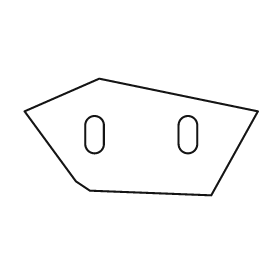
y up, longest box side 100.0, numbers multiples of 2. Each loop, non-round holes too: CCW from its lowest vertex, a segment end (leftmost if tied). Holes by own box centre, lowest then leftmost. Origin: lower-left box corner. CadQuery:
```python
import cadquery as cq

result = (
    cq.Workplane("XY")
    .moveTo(80.0, 0.0)
    .lineTo(100.0, 36.0)
    .lineTo(32.0, 50.0)
    .lineTo(0.0, 36.0)
    .lineTo(22.0, 6.0)
    .lineTo(28.0, 2.0)
    .close()
    .moveTo(26.0, 22.0)
    .threePointArc((30.0, 18.0), (34.0, 22.0))
    .lineTo(34.0, 30.0)
    .threePointArc((30.0, 34.0), (26.0, 30.0))
    .close()
    .moveTo(66.0, 22.0)
    .threePointArc((70.0, 18.0), (74.0, 22.0))
    .lineTo(74.0, 30.0)
    .threePointArc((70.0, 34.0), (66.0, 30.0))
    .close()
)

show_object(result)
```